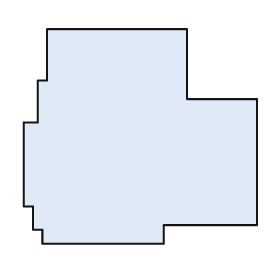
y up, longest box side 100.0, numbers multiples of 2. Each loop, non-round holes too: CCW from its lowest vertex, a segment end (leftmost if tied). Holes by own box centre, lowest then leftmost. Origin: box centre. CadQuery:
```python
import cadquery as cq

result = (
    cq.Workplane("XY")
    .moveTo(-42.0, -46.0)
    .lineTo(10.0, -46.0)
    .lineTo(10.0, -38.0)
    .lineTo(50.0, -38.0)
    .lineTo(50.0, 16.0)
    .lineTo(20.0, 16.0)
    .lineTo(20.0, 46.0)
    .lineTo(-40.0, 46.0)
    .lineTo(-40.0, 24.0)
    .lineTo(-44.0, 24.0)
    .lineTo(-44.0, 6.0)
    .lineTo(-50.0, 6.0)
    .lineTo(-50.0, -30.0)
    .lineTo(-46.0, -30.0)
    .lineTo(-46.0, -40.0)
    .lineTo(-42.0, -40.0)
    .close()
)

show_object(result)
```